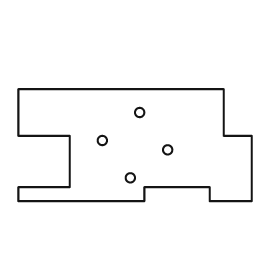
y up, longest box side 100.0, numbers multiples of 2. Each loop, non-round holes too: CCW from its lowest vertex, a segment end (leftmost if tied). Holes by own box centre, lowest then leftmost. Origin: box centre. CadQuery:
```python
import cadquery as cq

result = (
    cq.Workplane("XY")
    .moveTo(-50.0, -24.0)
    .lineTo(4.0, -24.0)
    .lineTo(4.0, -18.0)
    .lineTo(32.0, -18.0)
    .lineTo(32.0, -24.0)
    .lineTo(50.0, -24.0)
    .lineTo(50.0, 4.0)
    .lineTo(38.0, 4.0)
    .lineTo(38.0, 24.0)
    .lineTo(-50.0, 24.0)
    .lineTo(-50.0, 4.0)
    .lineTo(-28.0, 4.0)
    .lineTo(-28.0, -18.0)
    .lineTo(-50.0, -18.0)
    .close()
    .moveTo(-2.0, -14.0)
    .circle(2.0)
    .moveTo(14.0, -2.0)
    .circle(2.0)
    .moveTo(-14.0, 2.0)
    .circle(2.0)
    .moveTo(2.0, 14.0)
    .circle(2.0)
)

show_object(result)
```